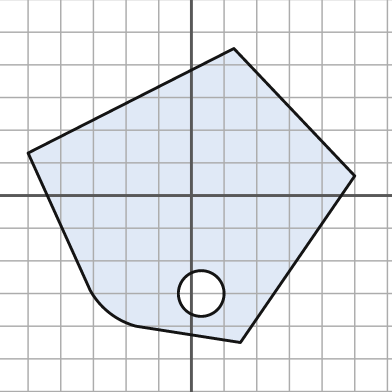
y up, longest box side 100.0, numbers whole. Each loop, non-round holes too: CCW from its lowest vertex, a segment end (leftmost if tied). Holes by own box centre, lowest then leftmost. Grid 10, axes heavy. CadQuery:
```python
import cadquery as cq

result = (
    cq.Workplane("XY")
    .moveTo(15.0, -45.0)
    .lineTo(50.0, 6.0)
    .lineTo(13.0, 45.0)
    .lineTo(-50.0, 13.0)
    .lineTo(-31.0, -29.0)
    .threePointArc((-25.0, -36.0), (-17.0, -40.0))
    .close()
    .moveTo(3.0, -30.0)
    .circle(7.0)
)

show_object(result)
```